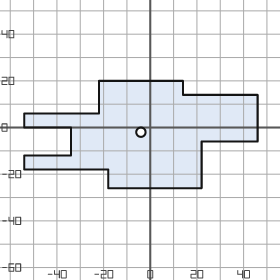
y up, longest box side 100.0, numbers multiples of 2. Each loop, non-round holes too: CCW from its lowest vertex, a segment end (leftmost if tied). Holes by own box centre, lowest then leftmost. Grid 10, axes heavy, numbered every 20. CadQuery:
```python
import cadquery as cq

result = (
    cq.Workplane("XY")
    .moveTo(-18.0, -26.0)
    .lineTo(22.0, -26.0)
    .lineTo(22.0, -6.0)
    .lineTo(46.0, -6.0)
    .lineTo(46.0, 14.0)
    .lineTo(14.0, 14.0)
    .lineTo(14.0, 20.0)
    .lineTo(-22.0, 20.0)
    .lineTo(-22.0, 6.0)
    .lineTo(-54.0, 6.0)
    .lineTo(-54.0, 0.0)
    .lineTo(-34.0, 0.0)
    .lineTo(-34.0, -12.0)
    .lineTo(-54.0, -12.0)
    .lineTo(-54.0, -18.0)
    .lineTo(-18.0, -18.0)
    .close()
    .moveTo(-4.0, -2.0)
    .circle(2.0)
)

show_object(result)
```